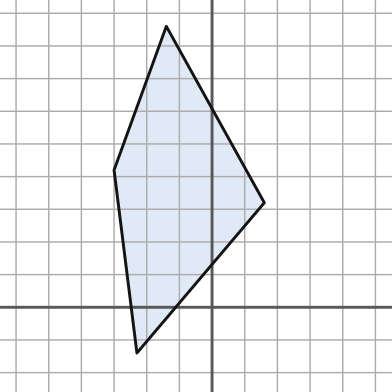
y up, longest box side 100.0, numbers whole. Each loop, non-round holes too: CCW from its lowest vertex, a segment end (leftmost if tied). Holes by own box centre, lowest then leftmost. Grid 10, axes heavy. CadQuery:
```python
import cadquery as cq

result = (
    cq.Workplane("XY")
    .moveTo(-23.0, -14.0)
    .lineTo(16.0, 32.0)
    .lineTo(-14.0, 86.0)
    .lineTo(-30.0, 42.0)
    .close()
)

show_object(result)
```